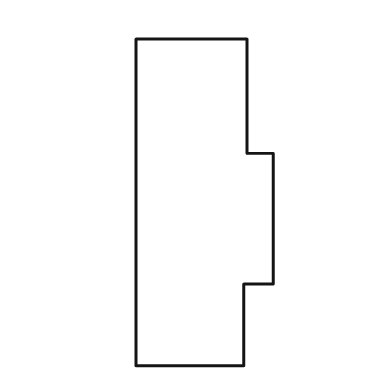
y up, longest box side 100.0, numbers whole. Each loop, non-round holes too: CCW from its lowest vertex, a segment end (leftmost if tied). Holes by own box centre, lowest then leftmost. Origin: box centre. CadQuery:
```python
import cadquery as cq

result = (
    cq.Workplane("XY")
    .moveTo(-21.0, -50.0)
    .lineTo(12.0, -50.0)
    .lineTo(12.0, -25.0)
    .lineTo(21.0, -25.0)
    .lineTo(21.0, 15.0)
    .lineTo(13.0, 15.0)
    .lineTo(13.0, 50.0)
    .lineTo(-21.0, 50.0)
    .close()
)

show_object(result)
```